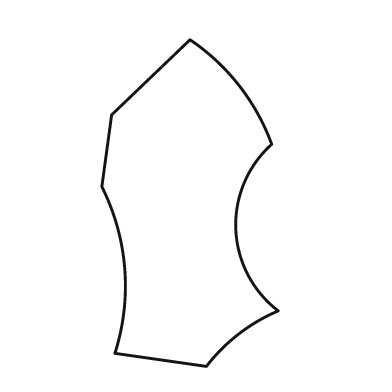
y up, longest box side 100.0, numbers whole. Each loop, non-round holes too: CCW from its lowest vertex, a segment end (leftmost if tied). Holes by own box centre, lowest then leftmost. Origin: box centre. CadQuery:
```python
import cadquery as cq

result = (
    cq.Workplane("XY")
    .moveTo(5.0, -50.0)
    .threePointArc((15.0, -40.0), (27.0, -33.0))
    .threePointArc((14.0, -8.0), (25.0, 18.0))
    .threePointArc((15.0, 36.0), (0.0, 50.0))
    .lineTo(-24.0, 27.0)
    .lineTo(-27.0, 5.0)
    .threePointArc((-20.0, -20.0), (-23.0, -46.0))
    .close()
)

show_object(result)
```